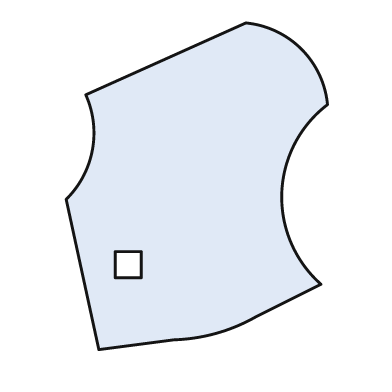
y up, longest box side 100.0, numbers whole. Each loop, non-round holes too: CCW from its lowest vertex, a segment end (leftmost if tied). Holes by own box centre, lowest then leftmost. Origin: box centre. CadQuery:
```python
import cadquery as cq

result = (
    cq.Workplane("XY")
    .moveTo(-30.0, -50.0)
    .lineTo(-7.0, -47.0)
    .threePointArc((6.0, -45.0), (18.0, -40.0))
    .lineTo(38.0, -30.0)
    .threePointArc((26.0, -2.0), (40.0, 25.0))
    .threePointArc((32.0, 42.0), (15.0, 50.0))
    .lineTo(-34.0, 28.0)
    .threePointArc((-32.0, 11.0), (-40.0, -4.0))
    .close()
    .moveTo(-25.0, -28.0)
    .lineTo(-17.0, -28.0)
    .lineTo(-17.0, -20.0)
    .lineTo(-25.0, -20.0)
    .close()
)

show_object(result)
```